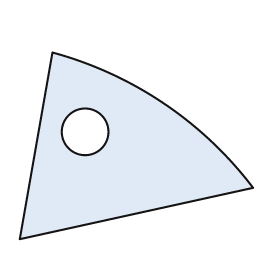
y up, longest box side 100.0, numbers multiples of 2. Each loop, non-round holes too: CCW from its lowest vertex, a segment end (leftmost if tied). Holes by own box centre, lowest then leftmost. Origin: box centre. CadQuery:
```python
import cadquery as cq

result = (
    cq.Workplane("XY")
    .moveTo(-50.0, -40.0)
    .lineTo(50.0, -18.0)
    .threePointArc((12.0, 18.0), (-36.0, 40.0))
    .close()
    .moveTo(-22.0, 6.0)
    .circle(10.0)
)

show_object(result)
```